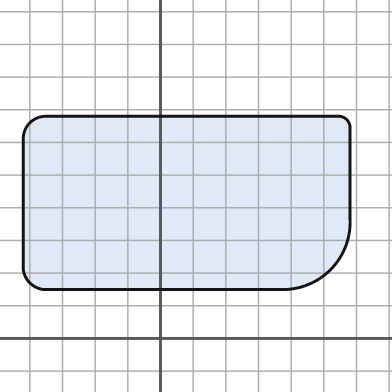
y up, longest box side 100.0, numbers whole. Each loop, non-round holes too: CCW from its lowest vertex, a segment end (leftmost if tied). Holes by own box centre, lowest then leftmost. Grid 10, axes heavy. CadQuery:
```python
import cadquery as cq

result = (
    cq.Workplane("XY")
    .moveTo(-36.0, 15.0)
    .lineTo(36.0, 15.0)
    .threePointArc((52.0, 21.0), (58.0, 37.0))
    .lineTo(58.0, 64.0)
    .threePointArc((57.0, 67.0), (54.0, 68.0))
    .lineTo(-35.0, 68.0)
    .threePointArc((-40.0, 66.0), (-42.0, 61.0))
    .lineTo(-42.0, 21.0)
    .threePointArc((-40.0, 17.0), (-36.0, 15.0))
    .close()
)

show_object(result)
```